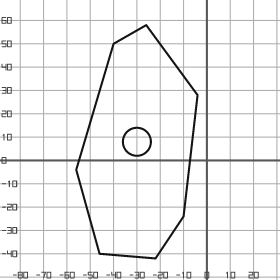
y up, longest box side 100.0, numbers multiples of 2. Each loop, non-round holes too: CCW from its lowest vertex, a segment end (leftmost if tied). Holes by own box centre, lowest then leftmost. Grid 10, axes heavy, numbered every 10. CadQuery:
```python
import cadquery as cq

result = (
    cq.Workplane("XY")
    .moveTo(-22.0, -42.0)
    .lineTo(-10.0, -24.0)
    .lineTo(-4.0, 28.0)
    .lineTo(-26.0, 58.0)
    .lineTo(-40.0, 50.0)
    .lineTo(-56.0, -4.0)
    .lineTo(-46.0, -40.0)
    .close()
    .moveTo(-30.0, 8.0)
    .circle(6.0)
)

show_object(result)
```